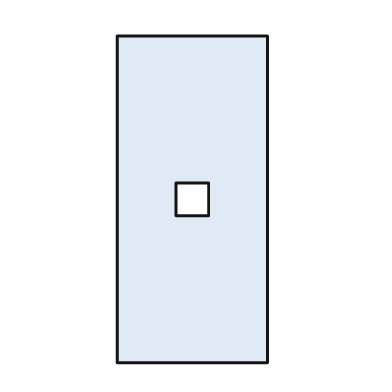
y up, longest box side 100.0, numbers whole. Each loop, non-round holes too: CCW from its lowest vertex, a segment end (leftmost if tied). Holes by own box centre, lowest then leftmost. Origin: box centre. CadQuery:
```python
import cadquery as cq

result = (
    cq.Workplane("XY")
    .moveTo(-23.0, -50.0)
    .lineTo(23.0, -50.0)
    .lineTo(23.0, 50.0)
    .lineTo(-23.0, 50.0)
    .close()
    .moveTo(-5.0, -5.0)
    .lineTo(5.0, -5.0)
    .lineTo(5.0, 5.0)
    .lineTo(-5.0, 5.0)
    .close()
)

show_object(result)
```